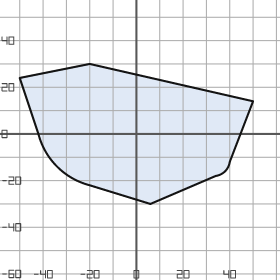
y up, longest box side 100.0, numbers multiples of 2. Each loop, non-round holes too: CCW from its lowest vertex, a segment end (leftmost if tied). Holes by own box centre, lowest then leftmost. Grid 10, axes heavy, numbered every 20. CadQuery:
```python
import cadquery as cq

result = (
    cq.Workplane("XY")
    .moveTo(6.0, -30.0)
    .lineTo(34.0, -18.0)
    .threePointArc((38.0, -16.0), (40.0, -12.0))
    .lineTo(50.0, 14.0)
    .lineTo(-20.0, 30.0)
    .lineTo(-50.0, 24.0)
    .lineTo(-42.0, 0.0)
    .threePointArc((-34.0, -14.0), (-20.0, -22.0))
    .close()
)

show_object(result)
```